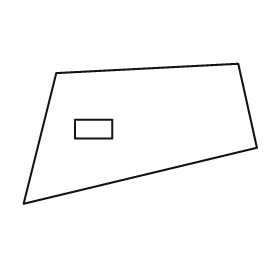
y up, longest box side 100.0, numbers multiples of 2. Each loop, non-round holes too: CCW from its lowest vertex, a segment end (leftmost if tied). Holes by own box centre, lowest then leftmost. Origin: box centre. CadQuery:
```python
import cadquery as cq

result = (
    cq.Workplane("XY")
    .moveTo(-50.0, -30.0)
    .lineTo(50.0, -6.0)
    .lineTo(42.0, 30.0)
    .lineTo(-36.0, 26.0)
    .close()
    .moveTo(-28.0, -2.0)
    .lineTo(-12.0, -2.0)
    .lineTo(-12.0, 6.0)
    .lineTo(-28.0, 6.0)
    .close()
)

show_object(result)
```